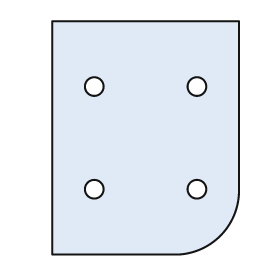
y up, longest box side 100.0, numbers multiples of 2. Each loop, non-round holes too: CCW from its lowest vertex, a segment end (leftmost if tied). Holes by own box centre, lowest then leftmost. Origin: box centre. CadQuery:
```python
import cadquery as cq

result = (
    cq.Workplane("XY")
    .moveTo(-40.0, -50.0)
    .lineTo(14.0, -50.0)
    .threePointArc((32.0, -42.0), (40.0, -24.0))
    .lineTo(40.0, 50.0)
    .lineTo(-40.0, 50.0)
    .close()
    .moveTo(-22.0, -22.0)
    .circle(4.0)
    .moveTo(22.0, -22.0)
    .circle(4.0)
    .moveTo(-22.0, 22.0)
    .circle(4.0)
    .moveTo(22.0, 22.0)
    .circle(4.0)
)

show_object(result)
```